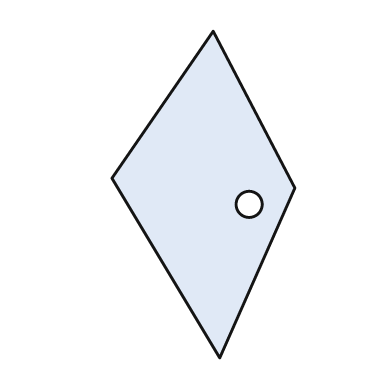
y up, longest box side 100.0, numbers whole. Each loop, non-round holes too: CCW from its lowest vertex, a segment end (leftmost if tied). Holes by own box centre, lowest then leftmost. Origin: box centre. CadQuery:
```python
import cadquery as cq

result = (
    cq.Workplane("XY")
    .moveTo(5.0, -50.0)
    .lineTo(28.0, 2.0)
    .lineTo(3.0, 50.0)
    .lineTo(-28.0, 5.0)
    .close()
    .moveTo(14.0, -3.0)
    .circle(4.0)
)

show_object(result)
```